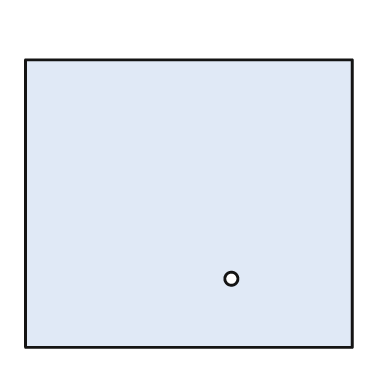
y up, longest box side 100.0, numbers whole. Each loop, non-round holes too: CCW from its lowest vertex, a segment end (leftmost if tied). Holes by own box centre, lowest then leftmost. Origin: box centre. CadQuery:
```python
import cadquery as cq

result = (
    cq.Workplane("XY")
    .moveTo(-50.0, -44.0)
    .lineTo(50.0, -44.0)
    .lineTo(50.0, 44.0)
    .lineTo(-50.0, 44.0)
    .close()
    .moveTo(13.0, -23.0)
    .circle(2.0)
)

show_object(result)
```